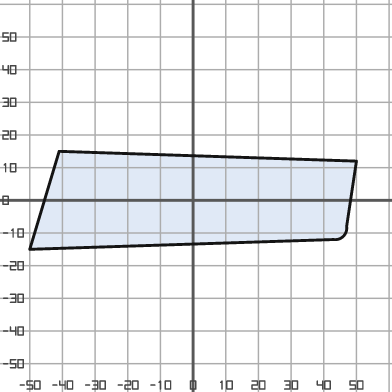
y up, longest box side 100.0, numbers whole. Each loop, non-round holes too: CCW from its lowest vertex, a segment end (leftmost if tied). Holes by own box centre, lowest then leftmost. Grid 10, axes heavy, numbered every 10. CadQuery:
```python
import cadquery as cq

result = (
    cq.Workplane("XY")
    .moveTo(-50.0, -15.0)
    .lineTo(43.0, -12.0)
    .threePointArc((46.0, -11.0), (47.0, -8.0))
    .lineTo(50.0, 12.0)
    .lineTo(-41.0, 15.0)
    .close()
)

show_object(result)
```